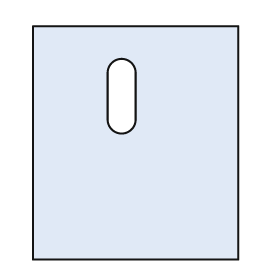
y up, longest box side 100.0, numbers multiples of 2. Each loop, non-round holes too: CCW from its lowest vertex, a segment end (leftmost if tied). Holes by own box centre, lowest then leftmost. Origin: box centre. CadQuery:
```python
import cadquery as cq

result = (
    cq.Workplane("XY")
    .moveTo(-44.0, -50.0)
    .lineTo(44.0, -50.0)
    .lineTo(44.0, 50.0)
    .lineTo(-44.0, 50.0)
    .close()
    .moveTo(-12.0, 10.0)
    .threePointArc((-6.0, 4.0), (0.0, 10.0))
    .lineTo(0.0, 30.0)
    .threePointArc((-6.0, 36.0), (-12.0, 30.0))
    .close()
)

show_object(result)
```